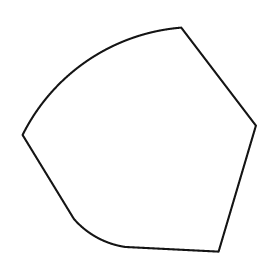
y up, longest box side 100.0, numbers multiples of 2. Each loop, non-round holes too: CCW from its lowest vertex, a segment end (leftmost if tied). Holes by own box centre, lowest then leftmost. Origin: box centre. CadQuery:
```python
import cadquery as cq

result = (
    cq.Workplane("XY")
    .moveTo(34.0, -48.0)
    .lineTo(50.0, 6.0)
    .lineTo(18.0, 48.0)
    .threePointArc((-22.0, 34.0), (-50.0, 2.0))
    .lineTo(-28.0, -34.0)
    .threePointArc((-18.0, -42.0), (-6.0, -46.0))
    .close()
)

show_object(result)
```